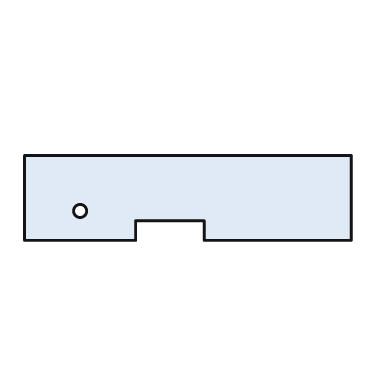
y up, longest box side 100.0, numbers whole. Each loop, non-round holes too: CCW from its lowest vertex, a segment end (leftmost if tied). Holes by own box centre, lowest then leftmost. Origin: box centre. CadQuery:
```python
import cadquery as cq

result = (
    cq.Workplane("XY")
    .moveTo(-50.0, -13.0)
    .lineTo(-16.0, -13.0)
    .lineTo(-16.0, -7.0)
    .lineTo(5.0, -7.0)
    .lineTo(5.0, -13.0)
    .lineTo(50.0, -13.0)
    .lineTo(50.0, 13.0)
    .lineTo(-50.0, 13.0)
    .close()
    .moveTo(-33.0, -4.0)
    .circle(2.0)
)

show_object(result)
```